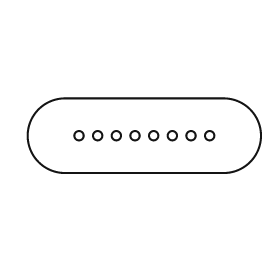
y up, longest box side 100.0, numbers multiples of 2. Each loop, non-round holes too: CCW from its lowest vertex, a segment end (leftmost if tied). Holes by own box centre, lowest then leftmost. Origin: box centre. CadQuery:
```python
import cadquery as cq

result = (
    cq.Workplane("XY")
    .moveTo(-34.0, -16.0)
    .lineTo(34.0, -16.0)
    .threePointArc((50.0, 0.0), (34.0, 16.0))
    .lineTo(-34.0, 16.0)
    .threePointArc((-50.0, 0.0), (-34.0, -16.0))
    .close()
    .moveTo(-28.0, 0.0)
    .circle(2.0)
    .moveTo(-20.0, 0.0)
    .circle(2.0)
    .moveTo(-12.0, 0.0)
    .circle(2.0)
    .moveTo(-4.0, 0.0)
    .circle(2.0)
    .moveTo(4.0, 0.0)
    .circle(2.0)
    .moveTo(12.0, 0.0)
    .circle(2.0)
    .moveTo(20.0, 0.0)
    .circle(2.0)
    .moveTo(28.0, 0.0)
    .circle(2.0)
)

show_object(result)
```